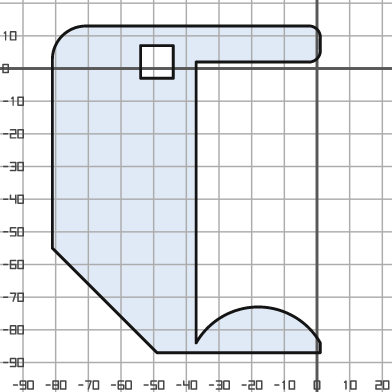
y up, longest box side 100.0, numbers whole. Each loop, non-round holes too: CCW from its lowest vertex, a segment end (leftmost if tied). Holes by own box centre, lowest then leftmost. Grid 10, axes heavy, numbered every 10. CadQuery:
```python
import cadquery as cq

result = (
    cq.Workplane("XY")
    .moveTo(-49.0, -87.0)
    .lineTo(1.0, -87.0)
    .lineTo(1.0, -84.0)
    .threePointArc((-18.0, -73.0), (-37.0, -84.0))
    .lineTo(-37.0, 2.0)
    .lineTo(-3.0, 2.0)
    .threePointArc((0.0, 3.0), (1.0, 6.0))
    .lineTo(1.0, 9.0)
    .threePointArc((0.0, 12.0), (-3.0, 13.0))
    .lineTo(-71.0, 13.0)
    .threePointArc((-78.0, 10.0), (-81.0, 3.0))
    .lineTo(-81.0, -55.0)
    .close()
    .moveTo(-54.0, -3.0)
    .lineTo(-44.0, -3.0)
    .lineTo(-44.0, 7.0)
    .lineTo(-54.0, 7.0)
    .close()
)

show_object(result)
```